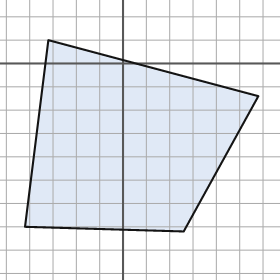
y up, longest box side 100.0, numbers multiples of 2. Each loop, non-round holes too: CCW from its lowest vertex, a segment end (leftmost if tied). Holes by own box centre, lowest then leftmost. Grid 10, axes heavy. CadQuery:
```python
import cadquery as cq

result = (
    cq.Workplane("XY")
    .moveTo(26.0, -72.0)
    .lineTo(58.0, -14.0)
    .lineTo(-32.0, 10.0)
    .lineTo(-42.0, -70.0)
    .close()
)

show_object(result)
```